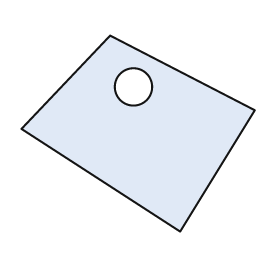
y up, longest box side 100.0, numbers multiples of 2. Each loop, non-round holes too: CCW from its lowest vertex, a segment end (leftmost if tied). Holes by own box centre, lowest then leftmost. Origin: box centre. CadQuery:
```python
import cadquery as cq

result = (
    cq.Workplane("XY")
    .moveTo(18.0, -42.0)
    .lineTo(50.0, 10.0)
    .lineTo(-12.0, 42.0)
    .lineTo(-50.0, 2.0)
    .close()
    .moveTo(-2.0, 20.0)
    .circle(8.0)
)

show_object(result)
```